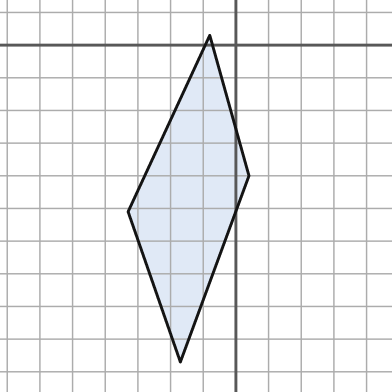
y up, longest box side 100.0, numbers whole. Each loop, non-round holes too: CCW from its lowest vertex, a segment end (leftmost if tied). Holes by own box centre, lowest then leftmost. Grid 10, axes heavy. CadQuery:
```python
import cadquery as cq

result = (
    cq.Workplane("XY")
    .moveTo(-17.0, -97.0)
    .lineTo(4.0, -40.0)
    .lineTo(-8.0, 3.0)
    .lineTo(-33.0, -51.0)
    .close()
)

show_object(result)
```